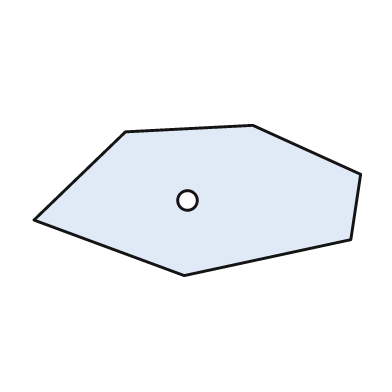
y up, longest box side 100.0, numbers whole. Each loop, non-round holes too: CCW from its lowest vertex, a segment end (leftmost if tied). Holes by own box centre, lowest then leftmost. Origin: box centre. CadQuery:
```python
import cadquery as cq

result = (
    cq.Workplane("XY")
    .moveTo(-4.0, -23.0)
    .lineTo(47.0, -12.0)
    .lineTo(50.0, 8.0)
    .lineTo(17.0, 23.0)
    .lineTo(-22.0, 21.0)
    .lineTo(-50.0, -6.0)
    .close()
    .moveTo(-3.0, 0.0)
    .circle(3.0)
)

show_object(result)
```